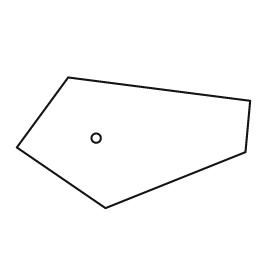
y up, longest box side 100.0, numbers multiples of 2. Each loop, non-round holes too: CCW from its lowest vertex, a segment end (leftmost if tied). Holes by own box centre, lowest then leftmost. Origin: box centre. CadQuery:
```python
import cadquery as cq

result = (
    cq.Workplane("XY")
    .moveTo(-12.0, -28.0)
    .lineTo(48.0, -4.0)
    .lineTo(50.0, 18.0)
    .lineTo(-28.0, 28.0)
    .lineTo(-50.0, -2.0)
    .close()
    .moveTo(-16.0, 2.0)
    .circle(2.0)
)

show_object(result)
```